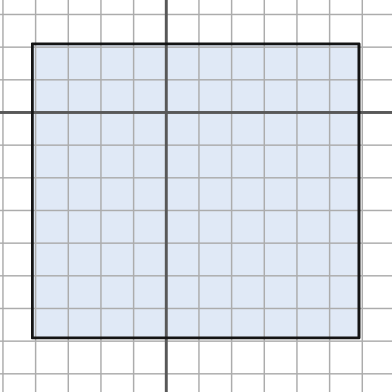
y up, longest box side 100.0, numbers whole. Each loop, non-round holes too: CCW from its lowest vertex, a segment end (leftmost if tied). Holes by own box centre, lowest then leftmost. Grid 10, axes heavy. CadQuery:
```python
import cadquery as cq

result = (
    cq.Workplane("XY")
    .moveTo(-41.0, -69.0)
    .lineTo(59.0, -69.0)
    .lineTo(59.0, 21.0)
    .lineTo(-41.0, 21.0)
    .close()
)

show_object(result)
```